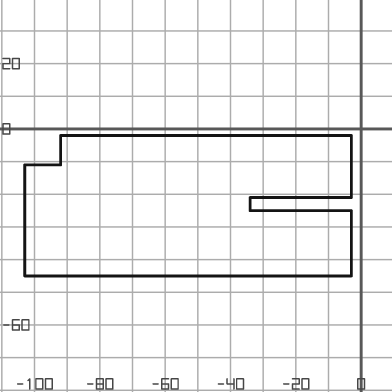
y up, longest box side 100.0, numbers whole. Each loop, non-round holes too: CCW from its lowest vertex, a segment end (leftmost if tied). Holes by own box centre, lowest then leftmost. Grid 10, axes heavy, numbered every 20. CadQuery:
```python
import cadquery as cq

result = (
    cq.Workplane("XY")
    .moveTo(-103.0, -45.0)
    .lineTo(-3.0, -45.0)
    .lineTo(-3.0, -25.0)
    .lineTo(-34.0, -25.0)
    .lineTo(-34.0, -21.0)
    .lineTo(-3.0, -21.0)
    .lineTo(-3.0, -2.0)
    .lineTo(-92.0, -2.0)
    .lineTo(-92.0, -11.0)
    .lineTo(-103.0, -11.0)
    .close()
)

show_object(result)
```